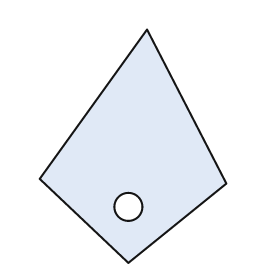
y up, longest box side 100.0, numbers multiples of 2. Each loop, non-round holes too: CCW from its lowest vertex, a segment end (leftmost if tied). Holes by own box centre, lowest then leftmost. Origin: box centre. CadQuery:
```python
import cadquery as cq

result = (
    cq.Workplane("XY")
    .moveTo(-2.0, -50.0)
    .lineTo(40.0, -16.0)
    .lineTo(6.0, 50.0)
    .lineTo(-40.0, -14.0)
    .close()
    .moveTo(-2.0, -26.0)
    .circle(6.0)
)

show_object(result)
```